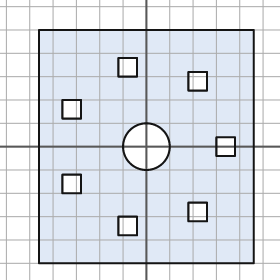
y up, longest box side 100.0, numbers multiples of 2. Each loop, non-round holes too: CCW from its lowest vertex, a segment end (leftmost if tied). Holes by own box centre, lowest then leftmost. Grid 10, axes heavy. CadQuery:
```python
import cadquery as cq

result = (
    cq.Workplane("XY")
    .moveTo(-46.0, -50.0)
    .lineTo(46.0, -50.0)
    .lineTo(46.0, 50.0)
    .lineTo(-46.0, 50.0)
    .close()
    .moveTo(-12.0, -38.0)
    .lineTo(-4.0, -38.0)
    .lineTo(-4.0, -30.0)
    .lineTo(-12.0, -30.0)
    .close()
    .moveTo(18.0, -32.0)
    .lineTo(26.0, -32.0)
    .lineTo(26.0, -24.0)
    .lineTo(18.0, -24.0)
    .close()
    .moveTo(-36.0, -20.0)
    .lineTo(-28.0, -20.0)
    .lineTo(-28.0, -12.0)
    .lineTo(-36.0, -12.0)
    .close()
    .moveTo(0.0, 0.0)
    .circle(10.0)
    .moveTo(30.0, -4.0)
    .lineTo(38.0, -4.0)
    .lineTo(38.0, 4.0)
    .lineTo(30.0, 4.0)
    .close()
    .moveTo(-36.0, 12.0)
    .lineTo(-28.0, 12.0)
    .lineTo(-28.0, 20.0)
    .lineTo(-36.0, 20.0)
    .close()
    .moveTo(18.0, 24.0)
    .lineTo(26.0, 24.0)
    .lineTo(26.0, 32.0)
    .lineTo(18.0, 32.0)
    .close()
    .moveTo(-12.0, 30.0)
    .lineTo(-4.0, 30.0)
    .lineTo(-4.0, 38.0)
    .lineTo(-12.0, 38.0)
    .close()
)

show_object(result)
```